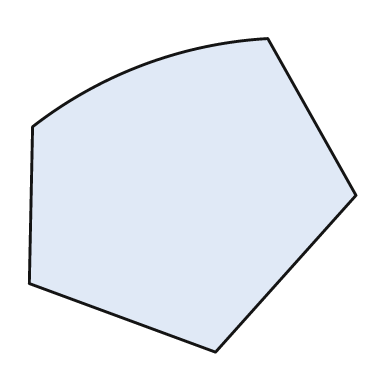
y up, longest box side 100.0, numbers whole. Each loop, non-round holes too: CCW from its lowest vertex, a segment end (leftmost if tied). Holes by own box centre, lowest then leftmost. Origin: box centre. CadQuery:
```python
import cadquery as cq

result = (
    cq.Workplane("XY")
    .moveTo(7.0, -48.0)
    .lineTo(50.0, 0.0)
    .lineTo(23.0, 48.0)
    .threePointArc((-15.0, 40.0), (-49.0, 21.0))
    .lineTo(-50.0, -27.0)
    .close()
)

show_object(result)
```